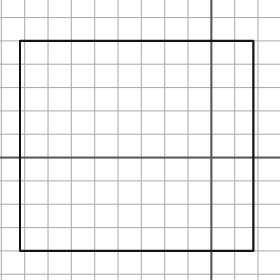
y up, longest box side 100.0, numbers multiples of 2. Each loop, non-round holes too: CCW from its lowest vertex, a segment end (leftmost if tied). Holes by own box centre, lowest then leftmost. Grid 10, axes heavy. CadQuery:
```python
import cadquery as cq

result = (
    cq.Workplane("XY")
    .moveTo(-82.0, -40.0)
    .lineTo(18.0, -40.0)
    .lineTo(18.0, 50.0)
    .lineTo(-82.0, 50.0)
    .close()
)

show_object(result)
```